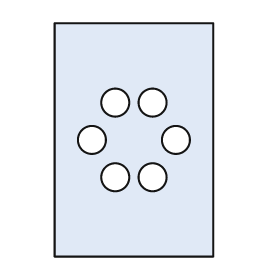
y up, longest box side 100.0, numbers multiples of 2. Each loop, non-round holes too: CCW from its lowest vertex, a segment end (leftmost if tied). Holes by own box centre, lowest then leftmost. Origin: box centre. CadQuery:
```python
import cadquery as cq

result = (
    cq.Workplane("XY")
    .moveTo(-34.0, -50.0)
    .lineTo(34.0, -50.0)
    .lineTo(34.0, 50.0)
    .lineTo(-34.0, 50.0)
    .close()
    .moveTo(-8.0, -16.0)
    .circle(6.0)
    .moveTo(8.0, -16.0)
    .circle(6.0)
    .moveTo(-18.0, 0.0)
    .circle(6.0)
    .moveTo(18.0, 0.0)
    .circle(6.0)
    .moveTo(-8.0, 16.0)
    .circle(6.0)
    .moveTo(8.0, 16.0)
    .circle(6.0)
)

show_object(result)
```